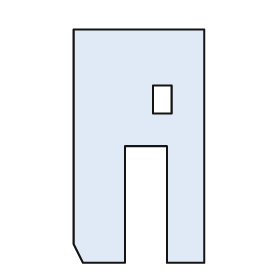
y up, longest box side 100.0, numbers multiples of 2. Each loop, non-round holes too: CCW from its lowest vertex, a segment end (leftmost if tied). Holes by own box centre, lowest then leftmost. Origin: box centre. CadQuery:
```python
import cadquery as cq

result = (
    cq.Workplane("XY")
    .moveTo(-24.0, -50.0)
    .lineTo(-6.0, -50.0)
    .lineTo(-6.0, 0.0)
    .lineTo(12.0, 0.0)
    .lineTo(12.0, -50.0)
    .lineTo(28.0, -50.0)
    .lineTo(28.0, 50.0)
    .lineTo(-28.0, 50.0)
    .lineTo(-28.0, -42.0)
    .close()
    .moveTo(6.0, 14.0)
    .lineTo(14.0, 14.0)
    .lineTo(14.0, 26.0)
    .lineTo(6.0, 26.0)
    .close()
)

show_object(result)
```